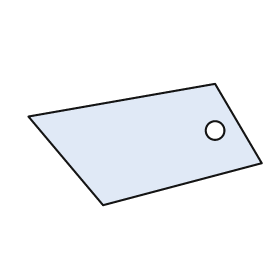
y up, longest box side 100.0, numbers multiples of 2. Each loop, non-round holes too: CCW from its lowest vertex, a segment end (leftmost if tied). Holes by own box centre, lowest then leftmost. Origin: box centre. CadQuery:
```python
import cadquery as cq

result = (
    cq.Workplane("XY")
    .moveTo(-18.0, -26.0)
    .lineTo(50.0, -8.0)
    .lineTo(30.0, 26.0)
    .lineTo(-50.0, 12.0)
    .close()
    .moveTo(30.0, 6.0)
    .circle(4.0)
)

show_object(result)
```